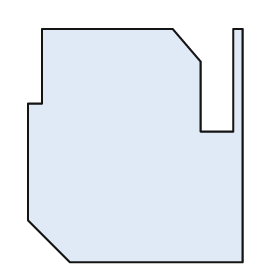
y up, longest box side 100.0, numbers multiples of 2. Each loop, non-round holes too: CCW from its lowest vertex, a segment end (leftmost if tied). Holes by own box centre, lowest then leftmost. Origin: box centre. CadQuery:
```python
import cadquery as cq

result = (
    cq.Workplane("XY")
    .moveTo(-28.0, -50.0)
    .lineTo(46.0, -50.0)
    .lineTo(46.0, 50.0)
    .lineTo(42.0, 50.0)
    .lineTo(42.0, 6.0)
    .lineTo(28.0, 6.0)
    .lineTo(28.0, 36.0)
    .lineTo(16.0, 50.0)
    .lineTo(-40.0, 50.0)
    .lineTo(-40.0, 18.0)
    .lineTo(-46.0, 18.0)
    .lineTo(-46.0, -32.0)
    .close()
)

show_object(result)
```